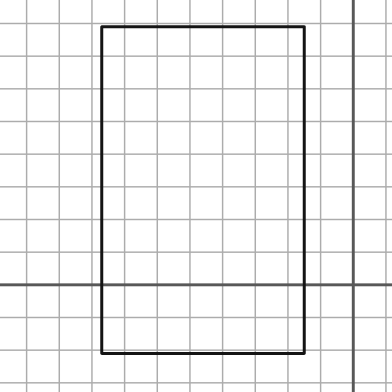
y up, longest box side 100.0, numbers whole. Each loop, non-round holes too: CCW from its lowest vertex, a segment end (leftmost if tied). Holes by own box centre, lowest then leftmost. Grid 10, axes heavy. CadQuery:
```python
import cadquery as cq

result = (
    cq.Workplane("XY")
    .moveTo(-77.0, -21.0)
    .lineTo(-15.0, -21.0)
    .lineTo(-15.0, 79.0)
    .lineTo(-77.0, 79.0)
    .close()
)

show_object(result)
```